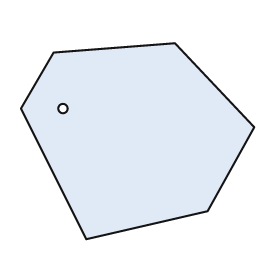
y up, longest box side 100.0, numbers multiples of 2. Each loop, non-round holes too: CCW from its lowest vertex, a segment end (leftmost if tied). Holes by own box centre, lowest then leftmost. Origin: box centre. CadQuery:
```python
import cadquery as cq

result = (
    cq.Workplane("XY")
    .moveTo(-22.0, -42.0)
    .lineTo(30.0, -30.0)
    .lineTo(50.0, 6.0)
    .lineTo(16.0, 42.0)
    .lineTo(-36.0, 38.0)
    .lineTo(-50.0, 14.0)
    .close()
    .moveTo(-32.0, 14.0)
    .circle(2.0)
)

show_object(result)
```